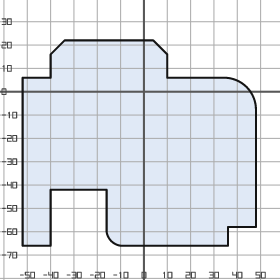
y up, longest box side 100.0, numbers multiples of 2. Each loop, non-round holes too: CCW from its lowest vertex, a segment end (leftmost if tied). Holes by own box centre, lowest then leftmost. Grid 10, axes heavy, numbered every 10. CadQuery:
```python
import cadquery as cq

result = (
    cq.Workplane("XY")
    .moveTo(-52.0, -66.0)
    .lineTo(-40.0, -66.0)
    .lineTo(-40.0, -42.0)
    .lineTo(-16.0, -42.0)
    .lineTo(-16.0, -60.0)
    .threePointArc((-14.0, -64.0), (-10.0, -66.0))
    .lineTo(36.0, -66.0)
    .lineTo(36.0, -58.0)
    .lineTo(48.0, -58.0)
    .lineTo(48.0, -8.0)
    .threePointArc((44.0, 2.0), (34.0, 6.0))
    .lineTo(10.0, 6.0)
    .lineTo(10.0, 16.0)
    .lineTo(4.0, 22.0)
    .lineTo(-34.0, 22.0)
    .lineTo(-40.0, 16.0)
    .lineTo(-40.0, 6.0)
    .lineTo(-52.0, 6.0)
    .close()
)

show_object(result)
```